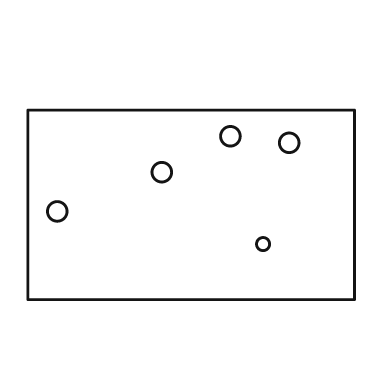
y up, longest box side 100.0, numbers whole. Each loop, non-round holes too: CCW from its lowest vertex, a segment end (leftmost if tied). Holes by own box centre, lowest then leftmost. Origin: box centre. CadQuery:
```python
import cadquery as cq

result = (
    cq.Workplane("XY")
    .moveTo(-50.0, -29.0)
    .lineTo(50.0, -29.0)
    .lineTo(50.0, 29.0)
    .lineTo(-50.0, 29.0)
    .close()
    .moveTo(22.0, -12.0)
    .circle(2.0)
    .moveTo(-41.0, -2.0)
    .circle(3.0)
    .moveTo(-9.0, 10.0)
    .circle(3.0)
    .moveTo(30.0, 19.0)
    .circle(3.0)
    .moveTo(12.0, 21.0)
    .circle(3.0)
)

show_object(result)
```